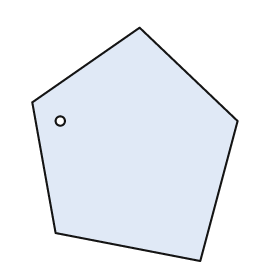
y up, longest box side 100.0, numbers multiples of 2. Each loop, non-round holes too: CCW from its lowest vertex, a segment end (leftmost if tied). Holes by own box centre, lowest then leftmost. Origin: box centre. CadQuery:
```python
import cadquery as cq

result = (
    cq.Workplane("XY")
    .moveTo(28.0, -50.0)
    .lineTo(44.0, 10.0)
    .lineTo(2.0, 50.0)
    .lineTo(-44.0, 18.0)
    .lineTo(-34.0, -38.0)
    .close()
    .moveTo(-32.0, 10.0)
    .circle(2.0)
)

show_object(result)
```